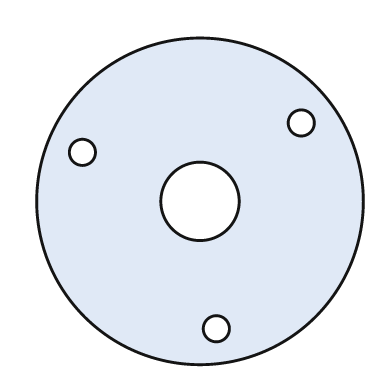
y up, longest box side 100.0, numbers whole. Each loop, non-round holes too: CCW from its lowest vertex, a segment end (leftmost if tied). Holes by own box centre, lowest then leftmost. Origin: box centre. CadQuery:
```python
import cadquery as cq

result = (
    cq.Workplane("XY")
    .moveTo(0.0, 0.0)
    .circle(50.0)
    .moveTo(5.0, -39.0)
    .circle(4.0)
    .moveTo(0.0, 0.0)
    .circle(12.0)
    .moveTo(-36.0, 15.0)
    .circle(4.0)
    .moveTo(31.0, 24.0)
    .circle(4.0)
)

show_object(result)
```